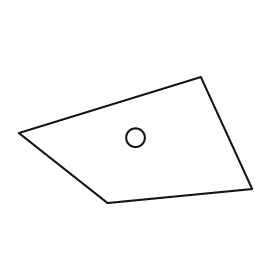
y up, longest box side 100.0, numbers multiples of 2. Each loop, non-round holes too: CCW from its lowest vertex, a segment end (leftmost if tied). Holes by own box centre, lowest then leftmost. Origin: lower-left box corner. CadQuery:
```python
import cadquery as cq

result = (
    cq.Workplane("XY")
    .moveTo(38.0, 0.0)
    .lineTo(100.0, 6.0)
    .lineTo(78.0, 54.0)
    .lineTo(0.0, 30.0)
    .close()
    .moveTo(50.0, 28.0)
    .circle(4.0)
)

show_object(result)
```